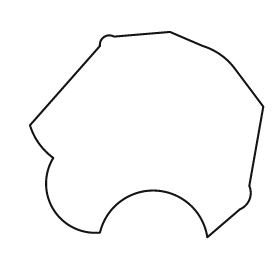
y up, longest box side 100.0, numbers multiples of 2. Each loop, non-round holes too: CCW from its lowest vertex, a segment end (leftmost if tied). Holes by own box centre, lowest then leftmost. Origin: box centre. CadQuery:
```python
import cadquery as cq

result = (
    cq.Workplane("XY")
    .moveTo(26.0, -44.0)
    .lineTo(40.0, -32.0)
    .threePointArc((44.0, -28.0), (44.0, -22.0))
    .lineTo(50.0, 12.0)
    .lineTo(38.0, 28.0)
    .threePointArc((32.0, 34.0), (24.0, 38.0))
    .lineTo(10.0, 44.0)
    .lineTo(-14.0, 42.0)
    .threePointArc((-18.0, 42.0), (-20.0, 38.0))
    .lineTo(-50.0, 4.0)
    .threePointArc((-46.0, -4.0), (-40.0, -10.0))
    .threePointArc((-40.0, -32.0), (-20.0, -42.0))
    .threePointArc((4.0, -24.0), (26.0, -44.0))
    .close()
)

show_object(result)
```